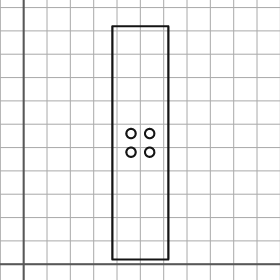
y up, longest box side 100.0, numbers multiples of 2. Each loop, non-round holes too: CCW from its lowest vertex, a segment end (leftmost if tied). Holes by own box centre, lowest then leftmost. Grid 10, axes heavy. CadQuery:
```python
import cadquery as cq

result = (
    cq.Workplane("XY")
    .moveTo(38.0, 2.0)
    .lineTo(62.0, 2.0)
    .lineTo(62.0, 102.0)
    .lineTo(38.0, 102.0)
    .close()
    .moveTo(46.0, 48.0)
    .circle(2.0)
    .moveTo(54.0, 48.0)
    .circle(2.0)
    .moveTo(46.0, 56.0)
    .circle(2.0)
    .moveTo(54.0, 56.0)
    .circle(2.0)
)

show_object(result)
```